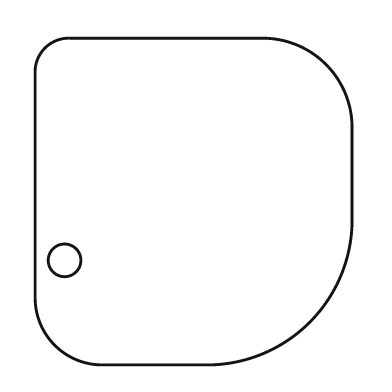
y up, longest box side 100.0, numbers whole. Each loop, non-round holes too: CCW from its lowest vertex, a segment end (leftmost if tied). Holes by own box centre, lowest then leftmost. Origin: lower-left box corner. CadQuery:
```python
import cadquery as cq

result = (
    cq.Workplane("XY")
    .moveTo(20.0, 0.0)
    .lineTo(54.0, 0.0)
    .threePointArc((84.0, 13.0), (97.0, 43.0))
    .lineTo(97.0, 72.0)
    .threePointArc((89.0, 92.0), (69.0, 100.0))
    .lineTo(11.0, 100.0)
    .threePointArc((3.0, 97.0), (0.0, 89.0))
    .lineTo(0.0, 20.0)
    .threePointArc((6.0, 6.0), (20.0, 0.0))
    .close()
    .moveTo(9.0, 32.0)
    .circle(5.0)
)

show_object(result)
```